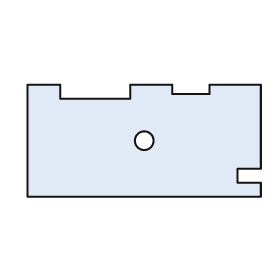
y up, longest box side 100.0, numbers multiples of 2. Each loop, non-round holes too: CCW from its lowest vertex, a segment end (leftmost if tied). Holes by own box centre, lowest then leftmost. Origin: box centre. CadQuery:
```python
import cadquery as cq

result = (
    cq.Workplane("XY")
    .moveTo(-50.0, -24.0)
    .lineTo(50.0, -24.0)
    .lineTo(50.0, -18.0)
    .lineTo(40.0, -18.0)
    .lineTo(40.0, -12.0)
    .lineTo(50.0, -12.0)
    .lineTo(50.0, 24.0)
    .lineTo(28.0, 24.0)
    .lineTo(28.0, 20.0)
    .lineTo(12.0, 20.0)
    .lineTo(12.0, 24.0)
    .lineTo(-6.0, 24.0)
    .lineTo(-6.0, 18.0)
    .lineTo(-36.0, 18.0)
    .lineTo(-36.0, 24.0)
    .lineTo(-50.0, 24.0)
    .close()
    .moveTo(0.0, 0.0)
    .circle(4.0)
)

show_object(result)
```